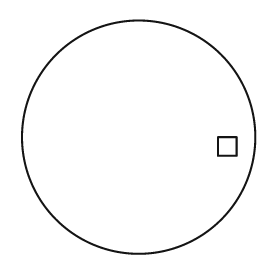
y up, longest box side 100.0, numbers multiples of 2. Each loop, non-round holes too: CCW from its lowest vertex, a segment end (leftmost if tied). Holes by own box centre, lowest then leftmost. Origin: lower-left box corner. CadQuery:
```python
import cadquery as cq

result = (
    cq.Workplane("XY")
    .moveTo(50.0, 50.0)
    .circle(50.0)
    .moveTo(84.0, 42.0)
    .lineTo(92.0, 42.0)
    .lineTo(92.0, 50.0)
    .lineTo(84.0, 50.0)
    .close()
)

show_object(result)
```